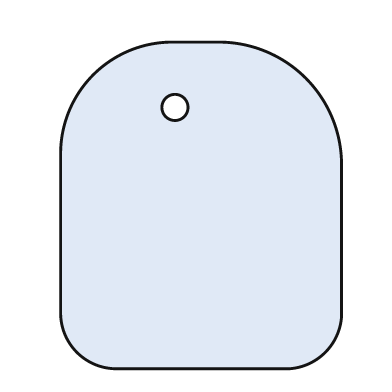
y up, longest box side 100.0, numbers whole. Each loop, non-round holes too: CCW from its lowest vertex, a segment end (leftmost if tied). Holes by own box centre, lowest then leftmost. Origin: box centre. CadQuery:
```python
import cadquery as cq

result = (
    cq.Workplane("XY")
    .moveTo(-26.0, -50.0)
    .lineTo(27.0, -50.0)
    .threePointArc((38.0, -45.0), (43.0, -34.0))
    .lineTo(43.0, 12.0)
    .threePointArc((32.0, 39.0), (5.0, 50.0))
    .lineTo(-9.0, 50.0)
    .threePointArc((-33.0, 40.0), (-43.0, 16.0))
    .lineTo(-43.0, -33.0)
    .threePointArc((-38.0, -45.0), (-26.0, -50.0))
    .close()
    .moveTo(-8.0, 30.0)
    .circle(4.0)
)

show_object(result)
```